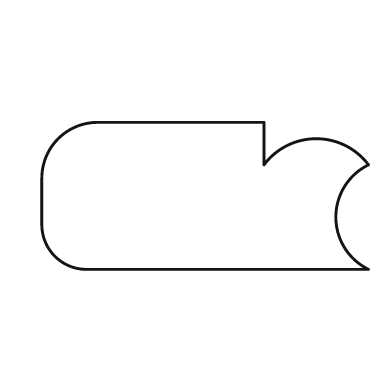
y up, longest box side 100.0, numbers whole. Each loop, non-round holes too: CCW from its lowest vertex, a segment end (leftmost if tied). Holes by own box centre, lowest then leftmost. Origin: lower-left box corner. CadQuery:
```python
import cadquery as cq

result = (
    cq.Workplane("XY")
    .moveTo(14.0, 0.0)
    .lineTo(100.0, 0.0)
    .threePointArc((90.0, 16.0), (100.0, 32.0))
    .threePointArc((84.0, 40.0), (68.0, 32.0))
    .lineTo(68.0, 45.0)
    .lineTo(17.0, 45.0)
    .threePointArc((5.0, 40.0), (0.0, 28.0))
    .lineTo(0.0, 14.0)
    .threePointArc((4.0, 4.0), (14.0, 0.0))
    .close()
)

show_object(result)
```